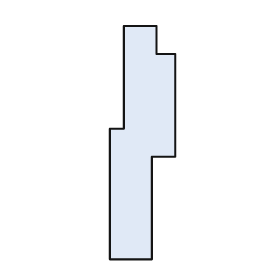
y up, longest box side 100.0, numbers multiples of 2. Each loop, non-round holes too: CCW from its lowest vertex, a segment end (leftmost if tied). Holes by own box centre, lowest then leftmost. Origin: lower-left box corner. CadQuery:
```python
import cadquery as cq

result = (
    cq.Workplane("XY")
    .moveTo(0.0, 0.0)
    .lineTo(18.0, 0.0)
    .lineTo(18.0, 44.0)
    .lineTo(28.0, 44.0)
    .lineTo(28.0, 88.0)
    .lineTo(20.0, 88.0)
    .lineTo(20.0, 100.0)
    .lineTo(6.0, 100.0)
    .lineTo(6.0, 56.0)
    .lineTo(0.0, 56.0)
    .close()
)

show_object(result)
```